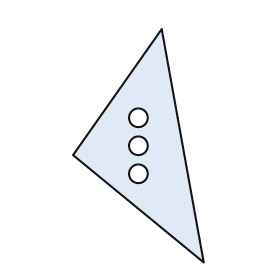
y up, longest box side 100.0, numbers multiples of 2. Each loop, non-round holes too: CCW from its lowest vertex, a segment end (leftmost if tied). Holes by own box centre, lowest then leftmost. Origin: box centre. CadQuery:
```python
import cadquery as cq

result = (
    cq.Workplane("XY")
    .moveTo(28.0, -50.0)
    .lineTo(10.0, 50.0)
    .lineTo(-28.0, -4.0)
    .close()
    .moveTo(0.0, -12.0)
    .circle(4.0)
    .moveTo(0.0, 0.0)
    .circle(4.0)
    .moveTo(0.0, 12.0)
    .circle(4.0)
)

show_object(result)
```